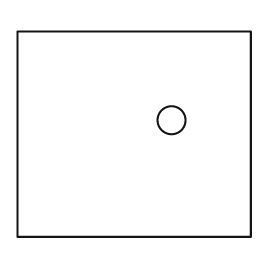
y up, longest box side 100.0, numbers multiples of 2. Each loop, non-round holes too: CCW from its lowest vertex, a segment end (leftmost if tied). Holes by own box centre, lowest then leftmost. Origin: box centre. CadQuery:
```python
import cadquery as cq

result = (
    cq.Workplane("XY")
    .moveTo(-50.0, -44.0)
    .lineTo(50.0, -44.0)
    .lineTo(50.0, 44.0)
    .lineTo(-50.0, 44.0)
    .close()
    .moveTo(16.0, 6.0)
    .circle(6.0)
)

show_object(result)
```